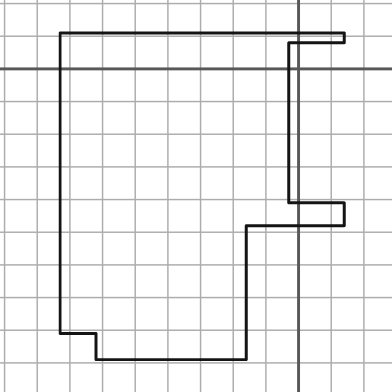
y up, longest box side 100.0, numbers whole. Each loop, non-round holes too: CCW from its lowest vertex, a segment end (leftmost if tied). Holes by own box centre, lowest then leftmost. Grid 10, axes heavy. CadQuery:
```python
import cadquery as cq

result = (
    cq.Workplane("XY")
    .moveTo(-62.0, -89.0)
    .lineTo(-16.0, -89.0)
    .lineTo(-16.0, -48.0)
    .lineTo(14.0, -48.0)
    .lineTo(14.0, -41.0)
    .lineTo(-3.0, -41.0)
    .lineTo(-3.0, 8.0)
    .lineTo(14.0, 8.0)
    .lineTo(14.0, 11.0)
    .lineTo(-73.0, 11.0)
    .lineTo(-73.0, -81.0)
    .lineTo(-62.0, -81.0)
    .close()
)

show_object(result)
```